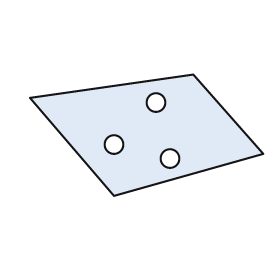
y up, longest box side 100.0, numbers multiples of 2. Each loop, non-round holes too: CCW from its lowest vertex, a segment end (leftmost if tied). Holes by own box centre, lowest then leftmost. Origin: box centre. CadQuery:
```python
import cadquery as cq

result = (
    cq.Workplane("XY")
    .moveTo(-14.0, -26.0)
    .lineTo(50.0, -8.0)
    .lineTo(20.0, 26.0)
    .lineTo(-50.0, 16.0)
    .close()
    .moveTo(10.0, -10.0)
    .circle(4.0)
    .moveTo(-14.0, -4.0)
    .circle(4.0)
    .moveTo(4.0, 14.0)
    .circle(4.0)
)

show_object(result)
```